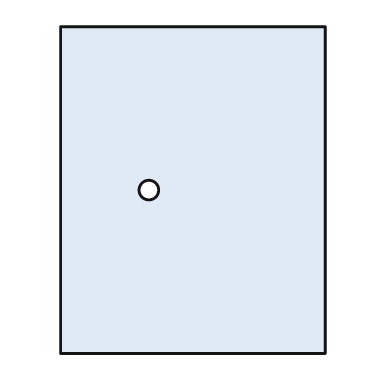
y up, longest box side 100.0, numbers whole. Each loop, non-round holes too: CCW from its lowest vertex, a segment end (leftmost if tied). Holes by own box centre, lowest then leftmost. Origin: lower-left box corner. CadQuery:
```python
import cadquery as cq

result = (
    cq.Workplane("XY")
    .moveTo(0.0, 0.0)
    .lineTo(81.0, 0.0)
    .lineTo(81.0, 100.0)
    .lineTo(0.0, 100.0)
    .close()
    .moveTo(27.0, 50.0)
    .circle(3.0)
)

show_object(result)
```